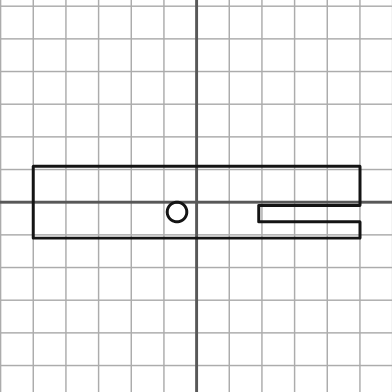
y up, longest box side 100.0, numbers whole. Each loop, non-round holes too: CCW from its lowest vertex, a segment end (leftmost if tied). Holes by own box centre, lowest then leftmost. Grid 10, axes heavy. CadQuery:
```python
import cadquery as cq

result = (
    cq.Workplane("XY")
    .moveTo(-50.0, -11.0)
    .lineTo(50.0, -11.0)
    .lineTo(50.0, -6.0)
    .lineTo(19.0, -6.0)
    .lineTo(19.0, -1.0)
    .lineTo(50.0, -1.0)
    .lineTo(50.0, 11.0)
    .lineTo(-50.0, 11.0)
    .close()
    .moveTo(-6.0, -3.0)
    .circle(3.0)
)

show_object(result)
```